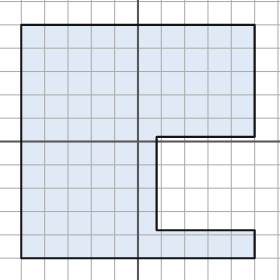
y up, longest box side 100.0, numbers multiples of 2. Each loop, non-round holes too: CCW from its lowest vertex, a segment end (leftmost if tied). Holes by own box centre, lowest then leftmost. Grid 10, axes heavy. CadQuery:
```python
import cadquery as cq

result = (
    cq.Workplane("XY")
    .moveTo(-50.0, -50.0)
    .lineTo(50.0, -50.0)
    .lineTo(50.0, -38.0)
    .lineTo(8.0, -38.0)
    .lineTo(8.0, 2.0)
    .lineTo(50.0, 2.0)
    .lineTo(50.0, 50.0)
    .lineTo(-50.0, 50.0)
    .close()
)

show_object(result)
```